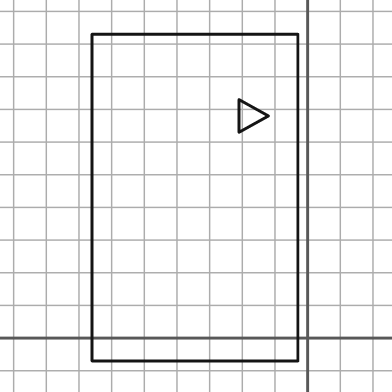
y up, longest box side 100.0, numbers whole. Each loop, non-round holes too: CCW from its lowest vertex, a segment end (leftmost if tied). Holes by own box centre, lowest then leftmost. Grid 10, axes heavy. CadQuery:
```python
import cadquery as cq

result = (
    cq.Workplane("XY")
    .moveTo(-66.0, -7.0)
    .lineTo(-3.0, -7.0)
    .lineTo(-3.0, 93.0)
    .lineTo(-66.0, 93.0)
    .close()
    .moveTo(-21.0, 63.0)
    .lineTo(-12.0, 68.0)
    .lineTo(-21.0, 73.0)
    .close()
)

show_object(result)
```